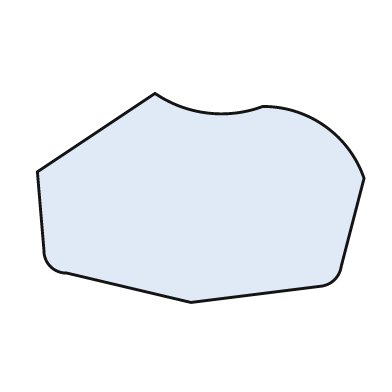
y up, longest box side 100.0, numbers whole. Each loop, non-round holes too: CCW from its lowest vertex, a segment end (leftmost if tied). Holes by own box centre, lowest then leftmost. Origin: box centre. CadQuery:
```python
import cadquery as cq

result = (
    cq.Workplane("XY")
    .moveTo(-3.0, -32.0)
    .lineTo(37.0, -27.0)
    .threePointArc((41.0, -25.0), (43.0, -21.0))
    .lineTo(50.0, 6.0)
    .threePointArc((38.0, 22.0), (19.0, 28.0))
    .threePointArc((2.0, 26.0), (-14.0, 32.0))
    .lineTo(-50.0, 8.0)
    .lineTo(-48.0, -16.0)
    .threePointArc((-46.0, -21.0), (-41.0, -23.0))
    .close()
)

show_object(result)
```